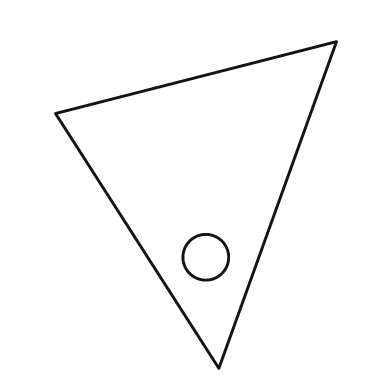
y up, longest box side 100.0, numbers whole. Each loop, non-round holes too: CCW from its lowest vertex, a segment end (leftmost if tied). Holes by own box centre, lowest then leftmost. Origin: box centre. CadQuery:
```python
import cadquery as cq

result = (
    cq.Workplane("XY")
    .moveTo(7.0, -50.0)
    .lineTo(43.0, 50.0)
    .lineTo(-43.0, 28.0)
    .close()
    .moveTo(3.0, -16.0)
    .circle(7.0)
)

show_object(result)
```